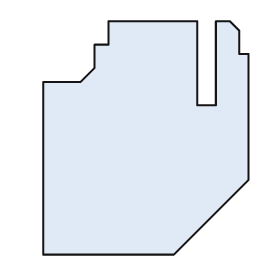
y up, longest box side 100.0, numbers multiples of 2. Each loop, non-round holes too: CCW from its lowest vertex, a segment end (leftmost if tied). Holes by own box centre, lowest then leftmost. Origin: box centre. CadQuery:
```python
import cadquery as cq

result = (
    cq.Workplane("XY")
    .moveTo(-44.0, -50.0)
    .lineTo(12.0, -50.0)
    .lineTo(44.0, -18.0)
    .lineTo(44.0, 36.0)
    .lineTo(40.0, 36.0)
    .lineTo(40.0, 46.0)
    .lineTo(36.0, 50.0)
    .lineTo(30.0, 50.0)
    .lineTo(30.0, 14.0)
    .lineTo(22.0, 14.0)
    .lineTo(22.0, 50.0)
    .lineTo(-16.0, 50.0)
    .lineTo(-16.0, 40.0)
    .lineTo(-22.0, 40.0)
    .lineTo(-22.0, 30.0)
    .lineTo(-28.0, 24.0)
    .lineTo(-44.0, 24.0)
    .close()
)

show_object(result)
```